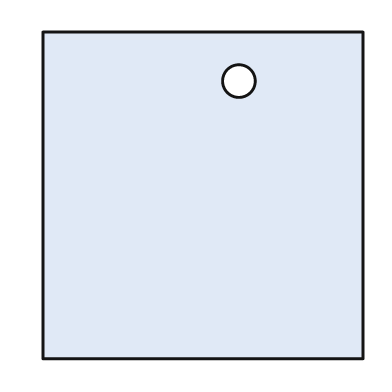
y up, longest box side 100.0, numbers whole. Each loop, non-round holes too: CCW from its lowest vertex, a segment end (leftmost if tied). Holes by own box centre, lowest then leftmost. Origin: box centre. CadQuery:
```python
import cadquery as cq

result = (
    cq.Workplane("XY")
    .moveTo(-49.0, -50.0)
    .lineTo(49.0, -50.0)
    .lineTo(49.0, 50.0)
    .lineTo(-49.0, 50.0)
    .close()
    .moveTo(11.0, 35.0)
    .circle(5.0)
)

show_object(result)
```